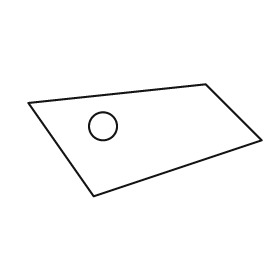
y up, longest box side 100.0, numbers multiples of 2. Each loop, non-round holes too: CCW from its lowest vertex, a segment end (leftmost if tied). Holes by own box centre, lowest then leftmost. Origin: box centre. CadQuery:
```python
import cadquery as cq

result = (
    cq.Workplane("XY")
    .moveTo(-22.0, -24.0)
    .lineTo(50.0, 0.0)
    .lineTo(26.0, 24.0)
    .lineTo(-50.0, 16.0)
    .close()
    .moveTo(-18.0, 6.0)
    .circle(6.0)
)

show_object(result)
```